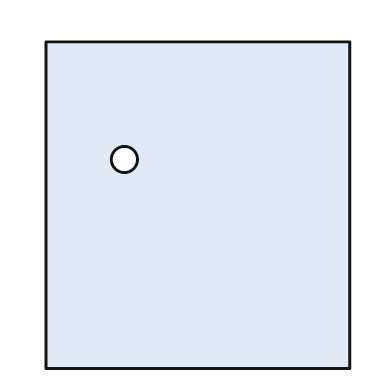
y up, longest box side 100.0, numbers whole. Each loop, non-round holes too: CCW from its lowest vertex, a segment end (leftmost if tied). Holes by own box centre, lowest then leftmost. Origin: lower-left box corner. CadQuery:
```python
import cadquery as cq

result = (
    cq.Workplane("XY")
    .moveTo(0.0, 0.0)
    .lineTo(93.0, 0.0)
    .lineTo(93.0, 100.0)
    .lineTo(0.0, 100.0)
    .close()
    .moveTo(24.0, 64.0)
    .circle(4.0)
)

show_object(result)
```